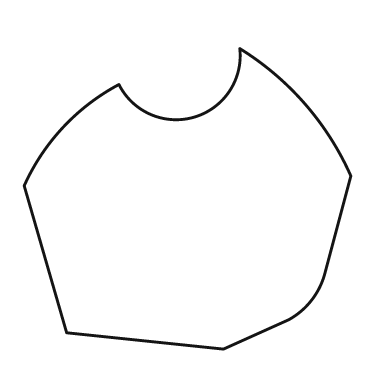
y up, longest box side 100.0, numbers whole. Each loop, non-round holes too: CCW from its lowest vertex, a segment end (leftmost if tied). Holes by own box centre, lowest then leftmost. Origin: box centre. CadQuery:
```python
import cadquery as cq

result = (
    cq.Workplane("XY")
    .moveTo(11.0, -46.0)
    .lineTo(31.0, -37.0)
    .threePointArc((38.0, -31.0), (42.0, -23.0))
    .lineTo(50.0, 7.0)
    .threePointArc((36.0, 29.0), (16.0, 46.0))
    .threePointArc((2.0, 25.0), (-21.0, 35.0))
    .threePointArc((-38.0, 22.0), (-50.0, 4.0))
    .lineTo(-37.0, -41.0)
    .close()
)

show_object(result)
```